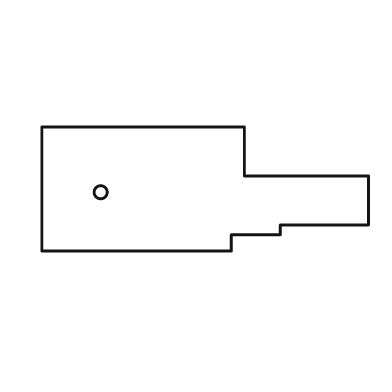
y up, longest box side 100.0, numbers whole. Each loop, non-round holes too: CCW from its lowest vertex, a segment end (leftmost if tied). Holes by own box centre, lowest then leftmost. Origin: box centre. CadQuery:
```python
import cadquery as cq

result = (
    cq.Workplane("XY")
    .moveTo(-50.0, -19.0)
    .lineTo(8.0, -19.0)
    .lineTo(8.0, -14.0)
    .lineTo(23.0, -14.0)
    .lineTo(23.0, -11.0)
    .lineTo(50.0, -11.0)
    .lineTo(50.0, 4.0)
    .lineTo(12.0, 4.0)
    .lineTo(12.0, 19.0)
    .lineTo(-50.0, 19.0)
    .close()
    .moveTo(-32.0, -1.0)
    .circle(2.0)
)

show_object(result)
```